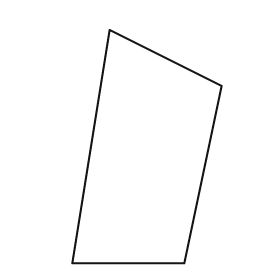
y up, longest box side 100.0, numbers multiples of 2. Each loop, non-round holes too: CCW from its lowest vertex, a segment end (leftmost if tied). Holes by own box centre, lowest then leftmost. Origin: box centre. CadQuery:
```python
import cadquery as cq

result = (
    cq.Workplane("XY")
    .moveTo(-32.0, -50.0)
    .lineTo(16.0, -50.0)
    .lineTo(32.0, 26.0)
    .lineTo(-16.0, 50.0)
    .close()
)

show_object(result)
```